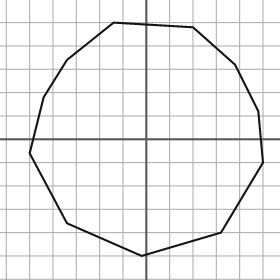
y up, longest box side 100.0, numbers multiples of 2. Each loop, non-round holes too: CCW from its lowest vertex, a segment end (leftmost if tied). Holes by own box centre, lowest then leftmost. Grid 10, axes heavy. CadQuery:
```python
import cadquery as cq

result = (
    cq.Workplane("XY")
    .moveTo(-2.0, -50.0)
    .lineTo(32.0, -40.0)
    .lineTo(50.0, -10.0)
    .lineTo(48.0, 12.0)
    .lineTo(38.0, 32.0)
    .lineTo(20.0, 48.0)
    .lineTo(-14.0, 50.0)
    .lineTo(-34.0, 34.0)
    .lineTo(-44.0, 18.0)
    .lineTo(-50.0, -6.0)
    .lineTo(-34.0, -36.0)
    .close()
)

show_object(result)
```